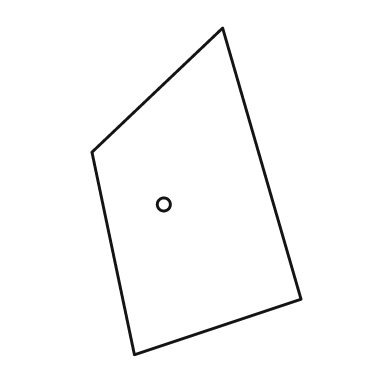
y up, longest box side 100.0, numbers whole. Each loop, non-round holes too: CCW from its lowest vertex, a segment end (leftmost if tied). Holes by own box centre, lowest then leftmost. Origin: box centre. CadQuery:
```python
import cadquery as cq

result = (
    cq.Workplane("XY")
    .moveTo(-19.0, -50.0)
    .lineTo(32.0, -33.0)
    .lineTo(8.0, 50.0)
    .lineTo(-32.0, 12.0)
    .close()
    .moveTo(-10.0, -4.0)
    .circle(2.0)
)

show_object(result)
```